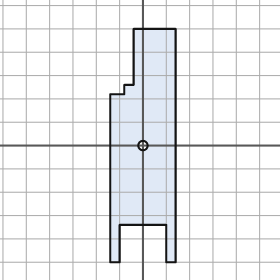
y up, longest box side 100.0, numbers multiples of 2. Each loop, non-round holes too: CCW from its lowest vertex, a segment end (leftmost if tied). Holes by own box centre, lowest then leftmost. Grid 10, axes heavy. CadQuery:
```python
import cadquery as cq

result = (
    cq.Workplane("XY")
    .moveTo(-14.0, -50.0)
    .lineTo(-10.0, -50.0)
    .lineTo(-10.0, -34.0)
    .lineTo(10.0, -34.0)
    .lineTo(10.0, -50.0)
    .lineTo(14.0, -50.0)
    .lineTo(14.0, 50.0)
    .lineTo(-4.0, 50.0)
    .lineTo(-4.0, 26.0)
    .lineTo(-8.0, 26.0)
    .lineTo(-8.0, 22.0)
    .lineTo(-14.0, 22.0)
    .close()
    .moveTo(0.0, 0.0)
    .circle(2.0)
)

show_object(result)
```